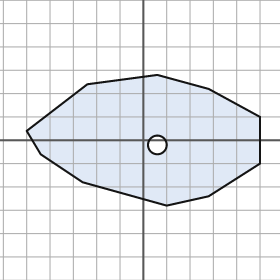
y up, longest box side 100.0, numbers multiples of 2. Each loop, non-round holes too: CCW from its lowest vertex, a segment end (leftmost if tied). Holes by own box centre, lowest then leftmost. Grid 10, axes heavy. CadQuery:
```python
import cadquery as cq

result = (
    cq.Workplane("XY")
    .moveTo(10.0, -28.0)
    .lineTo(28.0, -24.0)
    .lineTo(50.0, -10.0)
    .lineTo(50.0, 10.0)
    .lineTo(28.0, 22.0)
    .lineTo(6.0, 28.0)
    .lineTo(-24.0, 24.0)
    .lineTo(-50.0, 4.0)
    .lineTo(-44.0, -6.0)
    .lineTo(-26.0, -18.0)
    .close()
    .moveTo(6.0, -2.0)
    .circle(4.0)
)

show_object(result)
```